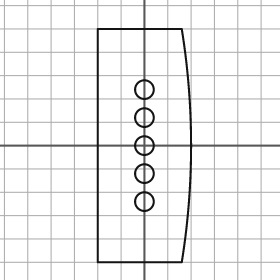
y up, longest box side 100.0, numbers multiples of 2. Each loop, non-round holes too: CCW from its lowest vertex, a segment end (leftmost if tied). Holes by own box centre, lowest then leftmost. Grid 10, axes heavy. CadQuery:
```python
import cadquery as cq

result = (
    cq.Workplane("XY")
    .moveTo(-20.0, -50.0)
    .lineTo(16.0, -50.0)
    .threePointArc((20.0, 0.0), (16.0, 50.0))
    .lineTo(-20.0, 50.0)
    .close()
    .moveTo(0.0, -24.0)
    .circle(4.0)
    .moveTo(0.0, -12.0)
    .circle(4.0)
    .moveTo(0.0, 0.0)
    .circle(4.0)
    .moveTo(0.0, 12.0)
    .circle(4.0)
    .moveTo(0.0, 24.0)
    .circle(4.0)
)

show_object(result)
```